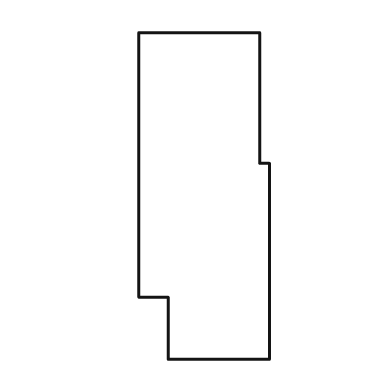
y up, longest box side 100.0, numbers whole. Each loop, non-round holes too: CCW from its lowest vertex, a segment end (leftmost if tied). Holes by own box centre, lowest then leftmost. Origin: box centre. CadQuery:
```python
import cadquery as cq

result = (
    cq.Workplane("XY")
    .moveTo(-11.0, -50.0)
    .lineTo(20.0, -50.0)
    .lineTo(20.0, 10.0)
    .lineTo(17.0, 10.0)
    .lineTo(17.0, 50.0)
    .lineTo(-20.0, 50.0)
    .lineTo(-20.0, -31.0)
    .lineTo(-11.0, -31.0)
    .close()
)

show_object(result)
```